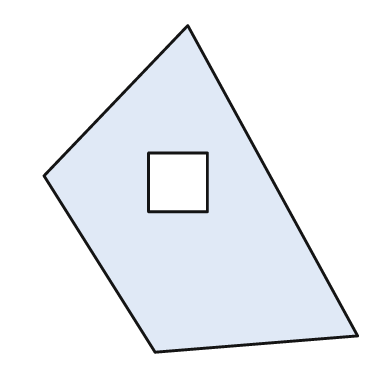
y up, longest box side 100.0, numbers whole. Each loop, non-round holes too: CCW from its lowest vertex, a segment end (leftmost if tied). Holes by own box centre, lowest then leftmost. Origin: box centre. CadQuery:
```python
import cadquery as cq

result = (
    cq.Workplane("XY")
    .moveTo(-14.0, -50.0)
    .lineTo(48.0, -45.0)
    .lineTo(-4.0, 50.0)
    .lineTo(-48.0, 4.0)
    .close()
    .moveTo(-16.0, -7.0)
    .lineTo(2.0, -7.0)
    .lineTo(2.0, 11.0)
    .lineTo(-16.0, 11.0)
    .close()
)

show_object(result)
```